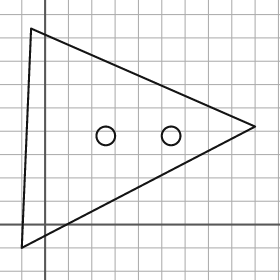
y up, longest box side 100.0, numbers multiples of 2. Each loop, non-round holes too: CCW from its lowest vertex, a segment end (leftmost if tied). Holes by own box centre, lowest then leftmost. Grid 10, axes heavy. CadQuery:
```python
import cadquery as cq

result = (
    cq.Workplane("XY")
    .moveTo(-10.0, -10.0)
    .lineTo(90.0, 42.0)
    .lineTo(-6.0, 84.0)
    .close()
    .moveTo(26.0, 38.0)
    .circle(4.0)
    .moveTo(54.0, 38.0)
    .circle(4.0)
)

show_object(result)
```